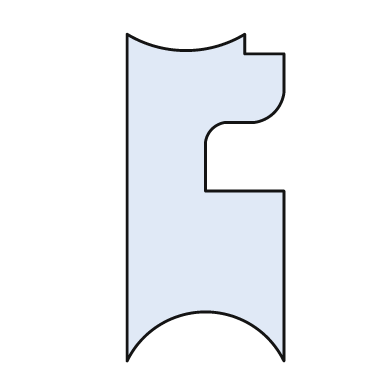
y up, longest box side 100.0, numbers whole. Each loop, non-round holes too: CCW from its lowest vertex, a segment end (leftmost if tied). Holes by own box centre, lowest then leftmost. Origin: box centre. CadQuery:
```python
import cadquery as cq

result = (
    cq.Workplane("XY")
    .moveTo(-24.0, -50.0)
    .threePointArc((0.0, -35.0), (24.0, -50.0))
    .lineTo(24.0, 2.0)
    .lineTo(0.0, 2.0)
    .lineTo(0.0, 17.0)
    .threePointArc((2.0, 21.0), (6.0, 23.0))
    .lineTo(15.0, 23.0)
    .threePointArc((21.0, 26.0), (24.0, 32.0))
    .lineTo(24.0, 44.0)
    .lineTo(12.0, 44.0)
    .lineTo(12.0, 50.0)
    .threePointArc((-6.0, 45.0), (-24.0, 50.0))
    .close()
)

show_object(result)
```